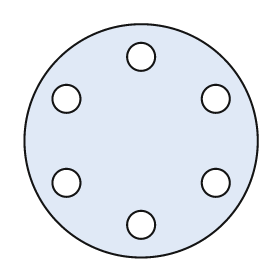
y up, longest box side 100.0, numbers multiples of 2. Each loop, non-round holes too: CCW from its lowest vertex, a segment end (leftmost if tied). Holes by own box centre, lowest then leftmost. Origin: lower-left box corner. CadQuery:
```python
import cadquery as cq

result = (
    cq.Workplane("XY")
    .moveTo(50.0, 50.0)
    .circle(50.0)
    .moveTo(50.0, 14.0)
    .circle(6.0)
    .moveTo(18.0, 32.0)
    .circle(6.0)
    .moveTo(82.0, 32.0)
    .circle(6.0)
    .moveTo(18.0, 68.0)
    .circle(6.0)
    .moveTo(82.0, 68.0)
    .circle(6.0)
    .moveTo(50.0, 86.0)
    .circle(6.0)
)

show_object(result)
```